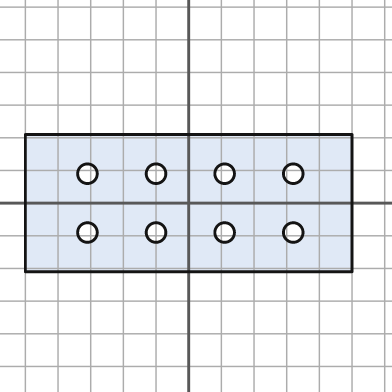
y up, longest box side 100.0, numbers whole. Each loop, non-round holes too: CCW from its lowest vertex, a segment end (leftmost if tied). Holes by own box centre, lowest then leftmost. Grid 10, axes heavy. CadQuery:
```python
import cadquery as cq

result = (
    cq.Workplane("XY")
    .moveTo(-50.0, -21.0)
    .lineTo(50.0, -21.0)
    .lineTo(50.0, 21.0)
    .lineTo(-50.0, 21.0)
    .close()
    .moveTo(-31.0, -9.0)
    .circle(3.0)
    .moveTo(-10.0, -9.0)
    .circle(3.0)
    .moveTo(11.0, -9.0)
    .circle(3.0)
    .moveTo(32.0, -9.0)
    .circle(3.0)
    .moveTo(-31.0, 9.0)
    .circle(3.0)
    .moveTo(-10.0, 9.0)
    .circle(3.0)
    .moveTo(11.0, 9.0)
    .circle(3.0)
    .moveTo(32.0, 9.0)
    .circle(3.0)
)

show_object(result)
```